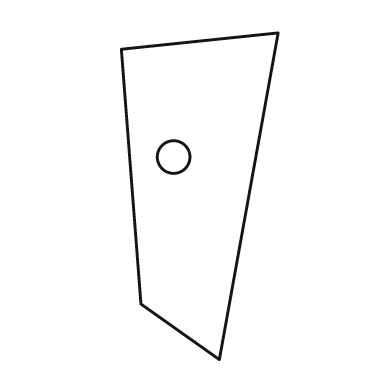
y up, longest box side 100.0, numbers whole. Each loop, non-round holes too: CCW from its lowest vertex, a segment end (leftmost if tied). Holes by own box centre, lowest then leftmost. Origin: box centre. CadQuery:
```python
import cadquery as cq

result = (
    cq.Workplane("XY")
    .moveTo(6.0, -50.0)
    .lineTo(24.0, 50.0)
    .lineTo(-24.0, 45.0)
    .lineTo(-18.0, -33.0)
    .close()
    .moveTo(-8.0, 12.0)
    .circle(5.0)
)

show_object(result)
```